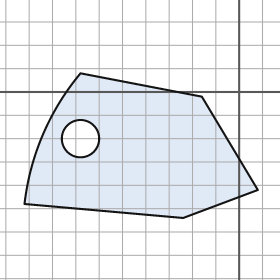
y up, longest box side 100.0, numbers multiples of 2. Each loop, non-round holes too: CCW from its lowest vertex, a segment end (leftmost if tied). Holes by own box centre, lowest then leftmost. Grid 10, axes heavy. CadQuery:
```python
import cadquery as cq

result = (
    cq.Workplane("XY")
    .moveTo(-24.0, -54.0)
    .lineTo(8.0, -42.0)
    .lineTo(-16.0, -2.0)
    .lineTo(-68.0, 8.0)
    .threePointArc((-84.0, -18.0), (-92.0, -48.0))
    .close()
    .moveTo(-68.0, -20.0)
    .circle(8.0)
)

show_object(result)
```